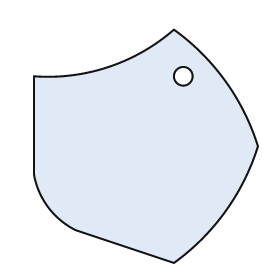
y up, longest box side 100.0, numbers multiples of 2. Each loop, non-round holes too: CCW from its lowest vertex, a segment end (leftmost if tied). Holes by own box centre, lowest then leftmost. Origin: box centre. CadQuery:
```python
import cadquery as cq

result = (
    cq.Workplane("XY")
    .moveTo(12.0, -50.0)
    .threePointArc((34.0, -28.0), (48.0, 0.0))
    .threePointArc((34.0, 28.0), (12.0, 50.0))
    .threePointArc((-16.0, 34.0), (-48.0, 30.0))
    .lineTo(-48.0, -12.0)
    .threePointArc((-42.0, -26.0), (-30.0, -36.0))
    .close()
    .moveTo(16.0, 30.0)
    .circle(4.0)
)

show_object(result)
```